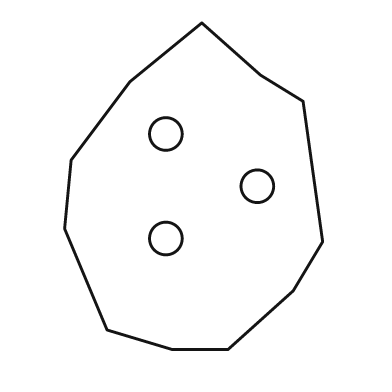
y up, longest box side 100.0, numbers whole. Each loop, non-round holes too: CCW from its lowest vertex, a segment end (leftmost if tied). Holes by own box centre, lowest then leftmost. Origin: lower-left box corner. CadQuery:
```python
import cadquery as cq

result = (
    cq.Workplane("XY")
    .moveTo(33.0, 0.0)
    .lineTo(50.0, 0.0)
    .lineTo(70.0, 18.0)
    .lineTo(79.0, 33.0)
    .lineTo(73.0, 76.0)
    .lineTo(60.0, 84.0)
    .lineTo(42.0, 100.0)
    .lineTo(20.0, 82.0)
    .lineTo(2.0, 58.0)
    .lineTo(0.0, 37.0)
    .lineTo(13.0, 6.0)
    .close()
    .moveTo(31.0, 34.0)
    .circle(5.0)
    .moveTo(59.0, 50.0)
    .circle(5.0)
    .moveTo(31.0, 66.0)
    .circle(5.0)
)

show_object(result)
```